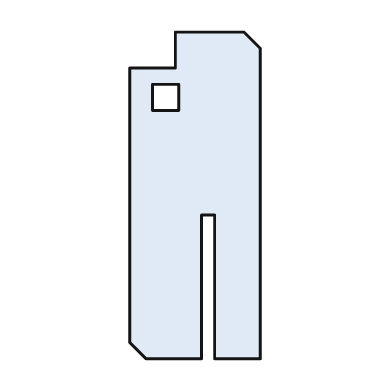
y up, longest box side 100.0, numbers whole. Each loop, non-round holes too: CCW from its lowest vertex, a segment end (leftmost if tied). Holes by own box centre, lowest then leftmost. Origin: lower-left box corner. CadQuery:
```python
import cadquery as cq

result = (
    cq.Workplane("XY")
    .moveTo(5.0, 0.0)
    .lineTo(22.0, 0.0)
    .lineTo(22.0, 44.0)
    .lineTo(26.0, 44.0)
    .lineTo(26.0, 0.0)
    .lineTo(40.0, 0.0)
    .lineTo(40.0, 95.0)
    .lineTo(35.0, 100.0)
    .lineTo(14.0, 100.0)
    .lineTo(14.0, 89.0)
    .lineTo(0.0, 89.0)
    .lineTo(0.0, 5.0)
    .close()
    .moveTo(7.0, 76.0)
    .lineTo(15.0, 76.0)
    .lineTo(15.0, 84.0)
    .lineTo(7.0, 84.0)
    .close()
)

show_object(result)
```